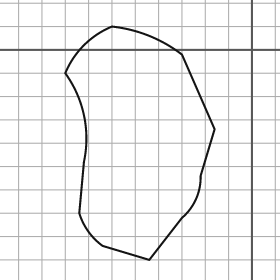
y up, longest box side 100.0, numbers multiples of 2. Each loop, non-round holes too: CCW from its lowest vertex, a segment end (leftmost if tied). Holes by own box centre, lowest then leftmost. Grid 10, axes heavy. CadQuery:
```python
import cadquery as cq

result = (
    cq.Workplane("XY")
    .moveTo(-44.0, -90.0)
    .lineTo(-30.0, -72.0)
    .threePointArc((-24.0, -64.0), (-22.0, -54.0))
    .lineTo(-16.0, -34.0)
    .lineTo(-30.0, -2.0)
    .threePointArc((-44.0, 6.0), (-60.0, 10.0))
    .threePointArc((-72.0, 2.0), (-80.0, -10.0))
    .threePointArc((-72.0, -28.0), (-72.0, -48.0))
    .lineTo(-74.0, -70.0)
    .threePointArc((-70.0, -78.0), (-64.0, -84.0))
    .close()
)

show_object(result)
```